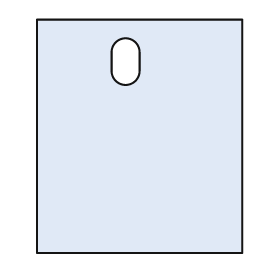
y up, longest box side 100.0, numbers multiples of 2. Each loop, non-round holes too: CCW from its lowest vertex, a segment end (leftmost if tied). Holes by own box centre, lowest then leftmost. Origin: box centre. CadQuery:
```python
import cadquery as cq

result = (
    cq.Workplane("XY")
    .moveTo(-44.0, -50.0)
    .lineTo(44.0, -50.0)
    .lineTo(44.0, 50.0)
    .lineTo(-44.0, 50.0)
    .close()
    .moveTo(-12.0, 28.0)
    .threePointArc((-6.0, 22.0), (0.0, 28.0))
    .lineTo(0.0, 36.0)
    .threePointArc((-6.0, 42.0), (-12.0, 36.0))
    .close()
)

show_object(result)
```